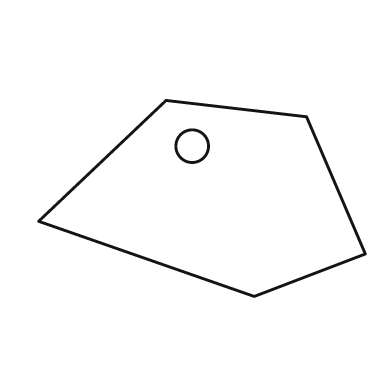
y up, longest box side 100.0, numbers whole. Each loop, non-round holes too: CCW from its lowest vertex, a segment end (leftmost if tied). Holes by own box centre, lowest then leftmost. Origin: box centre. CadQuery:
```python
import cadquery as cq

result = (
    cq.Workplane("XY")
    .moveTo(16.0, -30.0)
    .lineTo(50.0, -17.0)
    .lineTo(32.0, 25.0)
    .lineTo(-11.0, 30.0)
    .lineTo(-50.0, -7.0)
    .close()
    .moveTo(-3.0, 16.0)
    .circle(5.0)
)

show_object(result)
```